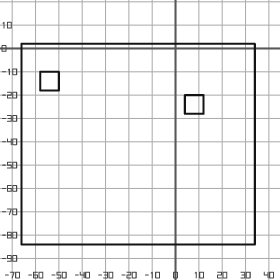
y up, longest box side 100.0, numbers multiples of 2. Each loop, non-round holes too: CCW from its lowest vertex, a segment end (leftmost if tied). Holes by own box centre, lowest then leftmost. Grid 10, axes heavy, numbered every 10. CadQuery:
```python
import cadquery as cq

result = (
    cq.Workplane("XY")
    .moveTo(-66.0, -84.0)
    .lineTo(34.0, -84.0)
    .lineTo(34.0, 2.0)
    .lineTo(-66.0, 2.0)
    .close()
    .moveTo(4.0, -28.0)
    .lineTo(12.0, -28.0)
    .lineTo(12.0, -20.0)
    .lineTo(4.0, -20.0)
    .close()
    .moveTo(-58.0, -18.0)
    .lineTo(-50.0, -18.0)
    .lineTo(-50.0, -10.0)
    .lineTo(-58.0, -10.0)
    .close()
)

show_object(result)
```